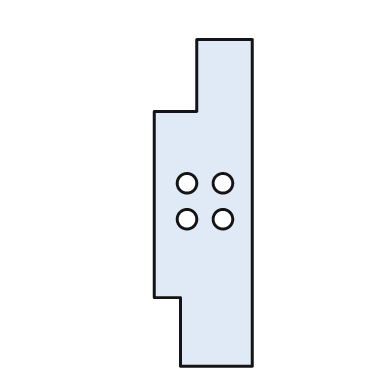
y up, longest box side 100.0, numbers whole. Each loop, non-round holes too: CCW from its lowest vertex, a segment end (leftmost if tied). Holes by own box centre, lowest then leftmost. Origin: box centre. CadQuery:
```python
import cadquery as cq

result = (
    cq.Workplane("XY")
    .moveTo(-7.0, -50.0)
    .lineTo(15.0, -50.0)
    .lineTo(15.0, 50.0)
    .lineTo(-2.0, 50.0)
    .lineTo(-2.0, 28.0)
    .lineTo(-15.0, 28.0)
    .lineTo(-15.0, -29.0)
    .lineTo(-7.0, -29.0)
    .close()
    .moveTo(-5.0, -5.0)
    .circle(3.0)
    .moveTo(6.0, -5.0)
    .circle(3.0)
    .moveTo(-5.0, 6.0)
    .circle(3.0)
    .moveTo(6.0, 6.0)
    .circle(3.0)
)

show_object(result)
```